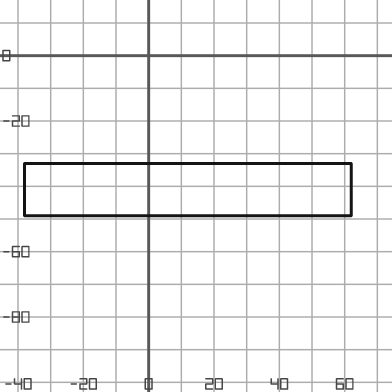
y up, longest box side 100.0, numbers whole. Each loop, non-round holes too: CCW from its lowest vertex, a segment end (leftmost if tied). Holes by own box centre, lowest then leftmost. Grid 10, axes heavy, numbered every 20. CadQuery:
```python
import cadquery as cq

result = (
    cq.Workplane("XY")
    .moveTo(-38.0, -49.0)
    .lineTo(62.0, -49.0)
    .lineTo(62.0, -33.0)
    .lineTo(-38.0, -33.0)
    .close()
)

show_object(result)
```